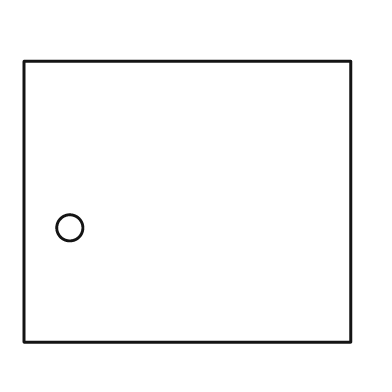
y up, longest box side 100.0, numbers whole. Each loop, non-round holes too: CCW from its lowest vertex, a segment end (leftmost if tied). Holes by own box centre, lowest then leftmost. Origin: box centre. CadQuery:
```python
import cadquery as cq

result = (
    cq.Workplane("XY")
    .moveTo(-50.0, -43.0)
    .lineTo(50.0, -43.0)
    .lineTo(50.0, 43.0)
    .lineTo(-50.0, 43.0)
    .close()
    .moveTo(-36.0, -8.0)
    .circle(4.0)
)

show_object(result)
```